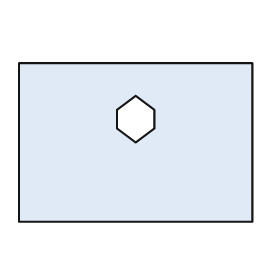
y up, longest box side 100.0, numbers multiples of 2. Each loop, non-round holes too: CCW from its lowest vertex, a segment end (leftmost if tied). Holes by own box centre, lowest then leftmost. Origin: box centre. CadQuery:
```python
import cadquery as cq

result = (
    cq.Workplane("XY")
    .moveTo(-50.0, -34.0)
    .lineTo(50.0, -34.0)
    .lineTo(50.0, 34.0)
    .lineTo(-50.0, 34.0)
    .close()
    .moveTo(0.0, 0.0)
    .lineTo(8.0, 6.0)
    .lineTo(8.0, 14.0)
    .lineTo(0.0, 20.0)
    .lineTo(-8.0, 14.0)
    .lineTo(-8.0, 6.0)
    .close()
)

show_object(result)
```